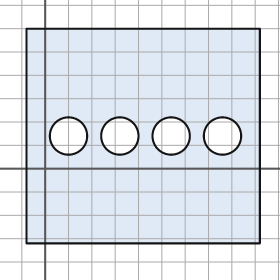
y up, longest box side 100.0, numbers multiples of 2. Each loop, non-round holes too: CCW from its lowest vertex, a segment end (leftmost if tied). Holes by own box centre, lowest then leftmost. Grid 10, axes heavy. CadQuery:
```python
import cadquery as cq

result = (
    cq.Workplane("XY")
    .moveTo(-8.0, -32.0)
    .lineTo(92.0, -32.0)
    .lineTo(92.0, 60.0)
    .lineTo(-8.0, 60.0)
    .close()
    .moveTo(10.0, 14.0)
    .circle(8.0)
    .moveTo(32.0, 14.0)
    .circle(8.0)
    .moveTo(54.0, 14.0)
    .circle(8.0)
    .moveTo(76.0, 14.0)
    .circle(8.0)
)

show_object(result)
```